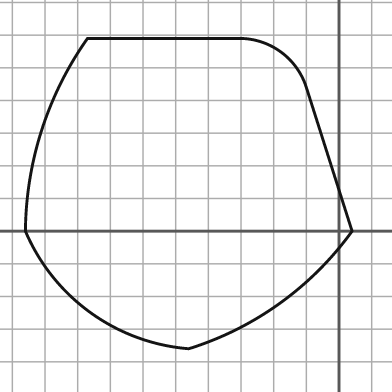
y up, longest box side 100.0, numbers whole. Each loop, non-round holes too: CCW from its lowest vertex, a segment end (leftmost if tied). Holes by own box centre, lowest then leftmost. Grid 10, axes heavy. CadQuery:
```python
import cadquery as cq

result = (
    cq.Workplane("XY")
    .moveTo(-46.0, -36.0)
    .threePointArc((-18.0, -22.0), (4.0, 0.0))
    .lineTo(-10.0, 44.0)
    .threePointArc((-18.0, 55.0), (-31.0, 59.0))
    .lineTo(-77.0, 59.0)
    .threePointArc((-91.0, 31.0), (-96.0, 0.0))
    .threePointArc((-76.0, -25.0), (-46.0, -36.0))
    .close()
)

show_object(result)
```